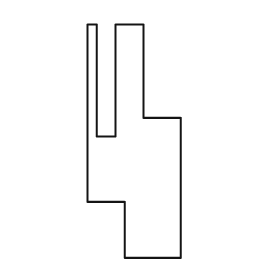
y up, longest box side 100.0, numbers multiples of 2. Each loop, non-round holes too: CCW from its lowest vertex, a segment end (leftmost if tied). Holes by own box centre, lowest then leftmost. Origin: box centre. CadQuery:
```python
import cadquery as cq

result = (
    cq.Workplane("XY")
    .moveTo(-4.0, -50.0)
    .lineTo(20.0, -50.0)
    .lineTo(20.0, 10.0)
    .lineTo(4.0, 10.0)
    .lineTo(4.0, 50.0)
    .lineTo(-8.0, 50.0)
    .lineTo(-8.0, 2.0)
    .lineTo(-16.0, 2.0)
    .lineTo(-16.0, 50.0)
    .lineTo(-20.0, 50.0)
    .lineTo(-20.0, -26.0)
    .lineTo(-4.0, -26.0)
    .close()
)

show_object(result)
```